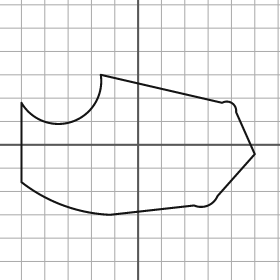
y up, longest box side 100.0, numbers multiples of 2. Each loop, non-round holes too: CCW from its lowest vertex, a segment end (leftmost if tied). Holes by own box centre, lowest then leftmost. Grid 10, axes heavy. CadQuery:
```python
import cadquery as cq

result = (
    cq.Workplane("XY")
    .moveTo(-12.0, -30.0)
    .lineTo(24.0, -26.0)
    .threePointArc((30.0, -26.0), (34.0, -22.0))
    .lineTo(50.0, -4.0)
    .lineTo(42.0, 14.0)
    .threePointArc((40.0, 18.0), (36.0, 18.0))
    .lineTo(-16.0, 30.0)
    .threePointArc((-28.0, 10.0), (-50.0, 18.0))
    .lineTo(-50.0, -16.0)
    .threePointArc((-32.0, -26.0), (-12.0, -30.0))
    .close()
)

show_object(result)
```